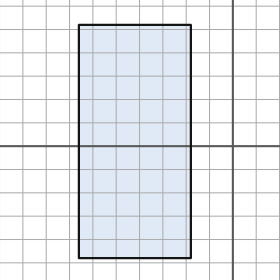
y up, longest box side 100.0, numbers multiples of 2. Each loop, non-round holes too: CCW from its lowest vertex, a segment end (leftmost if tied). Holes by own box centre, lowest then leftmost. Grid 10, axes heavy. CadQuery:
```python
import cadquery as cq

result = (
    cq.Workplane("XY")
    .moveTo(-66.0, -48.0)
    .lineTo(-18.0, -48.0)
    .lineTo(-18.0, 52.0)
    .lineTo(-66.0, 52.0)
    .close()
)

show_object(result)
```